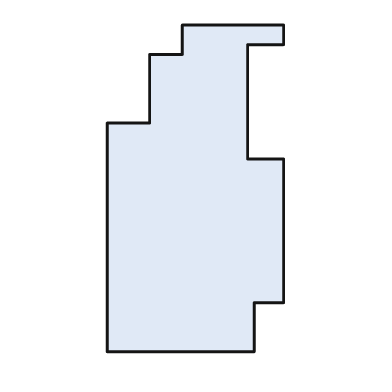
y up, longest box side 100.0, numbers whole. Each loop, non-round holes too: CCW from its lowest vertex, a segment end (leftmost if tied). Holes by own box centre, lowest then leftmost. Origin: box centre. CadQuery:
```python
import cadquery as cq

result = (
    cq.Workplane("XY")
    .moveTo(-27.0, -50.0)
    .lineTo(18.0, -50.0)
    .lineTo(18.0, -35.0)
    .lineTo(27.0, -35.0)
    .lineTo(27.0, 9.0)
    .lineTo(16.0, 9.0)
    .lineTo(16.0, 44.0)
    .lineTo(27.0, 44.0)
    .lineTo(27.0, 50.0)
    .lineTo(-4.0, 50.0)
    .lineTo(-4.0, 41.0)
    .lineTo(-14.0, 41.0)
    .lineTo(-14.0, 20.0)
    .lineTo(-27.0, 20.0)
    .close()
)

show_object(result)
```